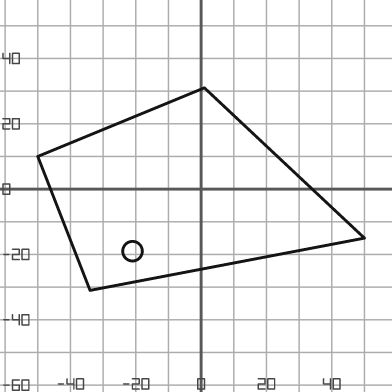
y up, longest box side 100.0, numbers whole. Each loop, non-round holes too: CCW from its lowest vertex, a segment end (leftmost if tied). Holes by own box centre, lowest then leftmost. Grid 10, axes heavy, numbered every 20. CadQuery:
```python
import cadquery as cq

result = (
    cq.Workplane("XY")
    .moveTo(-34.0, -31.0)
    .lineTo(50.0, -15.0)
    .lineTo(1.0, 31.0)
    .lineTo(-50.0, 10.0)
    .close()
    .moveTo(-21.0, -19.0)
    .circle(3.0)
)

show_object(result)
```